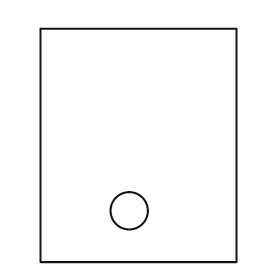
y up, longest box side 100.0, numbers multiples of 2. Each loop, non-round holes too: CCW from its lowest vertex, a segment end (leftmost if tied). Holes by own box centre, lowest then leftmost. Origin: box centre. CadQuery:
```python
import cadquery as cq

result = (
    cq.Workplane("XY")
    .moveTo(-42.0, -50.0)
    .lineTo(42.0, -50.0)
    .lineTo(42.0, 50.0)
    .lineTo(-42.0, 50.0)
    .close()
    .moveTo(-4.0, -28.0)
    .circle(8.0)
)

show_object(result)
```